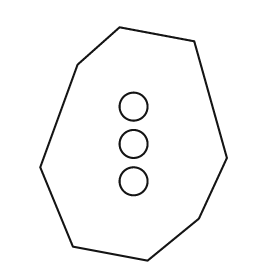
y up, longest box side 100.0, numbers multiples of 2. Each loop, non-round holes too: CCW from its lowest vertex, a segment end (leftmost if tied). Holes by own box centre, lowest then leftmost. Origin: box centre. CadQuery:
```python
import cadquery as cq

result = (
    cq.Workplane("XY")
    .moveTo(6.0, -50.0)
    .lineTo(28.0, -32.0)
    .lineTo(40.0, -6.0)
    .lineTo(26.0, 44.0)
    .lineTo(-6.0, 50.0)
    .lineTo(-24.0, 34.0)
    .lineTo(-40.0, -10.0)
    .lineTo(-26.0, -44.0)
    .close()
    .moveTo(0.0, -16.0)
    .circle(6.0)
    .moveTo(0.0, 0.0)
    .circle(6.0)
    .moveTo(0.0, 16.0)
    .circle(6.0)
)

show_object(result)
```